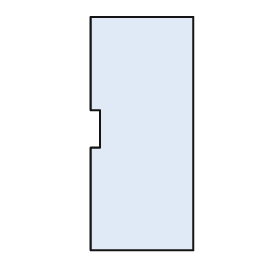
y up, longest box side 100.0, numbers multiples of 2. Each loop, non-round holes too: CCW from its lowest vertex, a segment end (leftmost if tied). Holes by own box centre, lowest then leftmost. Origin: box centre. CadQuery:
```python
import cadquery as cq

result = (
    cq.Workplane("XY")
    .moveTo(-22.0, -50.0)
    .lineTo(22.0, -50.0)
    .lineTo(22.0, 50.0)
    .lineTo(-22.0, 50.0)
    .lineTo(-22.0, 10.0)
    .lineTo(-18.0, 10.0)
    .lineTo(-18.0, -6.0)
    .lineTo(-22.0, -6.0)
    .close()
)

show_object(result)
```